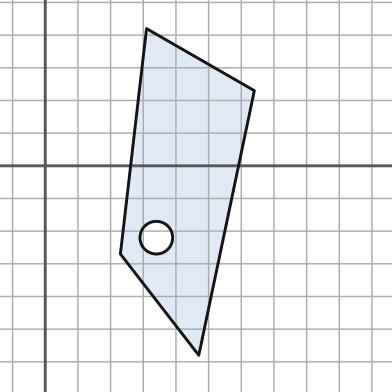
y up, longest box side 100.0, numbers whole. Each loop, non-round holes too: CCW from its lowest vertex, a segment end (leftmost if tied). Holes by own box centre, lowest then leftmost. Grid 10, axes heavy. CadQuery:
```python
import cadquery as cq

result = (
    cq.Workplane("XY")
    .moveTo(47.0, -58.0)
    .lineTo(64.0, 23.0)
    .lineTo(31.0, 42.0)
    .lineTo(23.0, -27.0)
    .close()
    .moveTo(34.0, -22.0)
    .circle(5.0)
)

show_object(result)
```